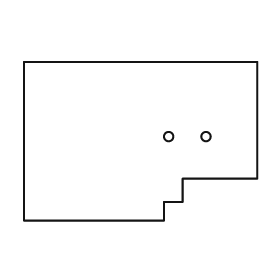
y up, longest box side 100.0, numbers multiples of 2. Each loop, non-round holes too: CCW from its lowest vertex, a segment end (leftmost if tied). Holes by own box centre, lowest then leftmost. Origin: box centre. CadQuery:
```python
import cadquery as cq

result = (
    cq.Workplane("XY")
    .moveTo(-50.0, -34.0)
    .lineTo(10.0, -34.0)
    .lineTo(10.0, -26.0)
    .lineTo(18.0, -26.0)
    .lineTo(18.0, -16.0)
    .lineTo(50.0, -16.0)
    .lineTo(50.0, 34.0)
    .lineTo(-50.0, 34.0)
    .close()
    .moveTo(12.0, 2.0)
    .circle(2.0)
    .moveTo(28.0, 2.0)
    .circle(2.0)
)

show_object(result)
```